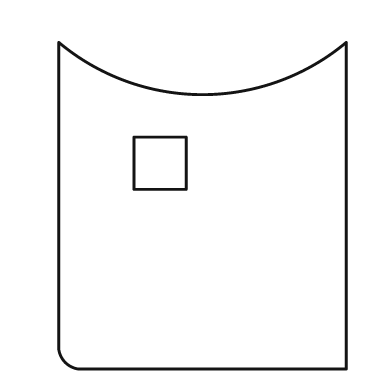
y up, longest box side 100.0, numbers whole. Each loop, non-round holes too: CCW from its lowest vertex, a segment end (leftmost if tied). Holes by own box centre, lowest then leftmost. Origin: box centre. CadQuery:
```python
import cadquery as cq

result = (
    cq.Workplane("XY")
    .moveTo(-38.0, -50.0)
    .lineTo(44.0, -50.0)
    .lineTo(44.0, 50.0)
    .threePointArc((0.0, 34.0), (-44.0, 50.0))
    .lineTo(-44.0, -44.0)
    .threePointArc((-42.0, -48.0), (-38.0, -50.0))
    .close()
    .moveTo(-21.0, 5.0)
    .lineTo(-5.0, 5.0)
    .lineTo(-5.0, 21.0)
    .lineTo(-21.0, 21.0)
    .close()
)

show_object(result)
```